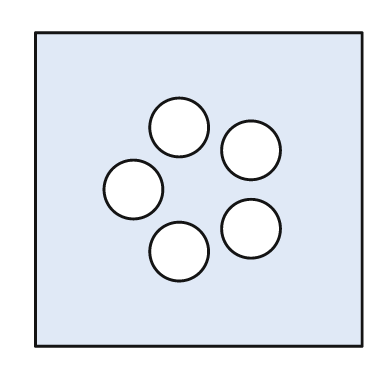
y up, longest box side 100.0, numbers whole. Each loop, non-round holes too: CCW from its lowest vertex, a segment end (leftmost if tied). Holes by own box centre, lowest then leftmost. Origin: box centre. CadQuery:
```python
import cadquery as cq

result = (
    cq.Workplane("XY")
    .moveTo(-50.0, -48.0)
    .lineTo(50.0, -48.0)
    .lineTo(50.0, 48.0)
    .lineTo(-50.0, 48.0)
    .close()
    .moveTo(-6.0, -19.0)
    .circle(9.0)
    .moveTo(16.0, -12.0)
    .circle(9.0)
    .moveTo(-20.0, 0.0)
    .circle(9.0)
    .moveTo(16.0, 12.0)
    .circle(9.0)
    .moveTo(-6.0, 19.0)
    .circle(9.0)
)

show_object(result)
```